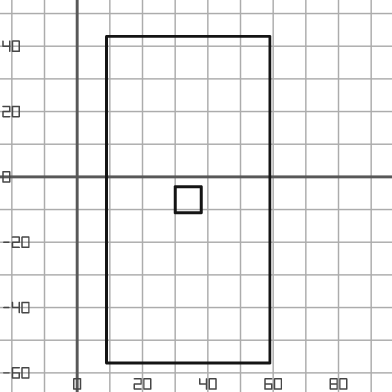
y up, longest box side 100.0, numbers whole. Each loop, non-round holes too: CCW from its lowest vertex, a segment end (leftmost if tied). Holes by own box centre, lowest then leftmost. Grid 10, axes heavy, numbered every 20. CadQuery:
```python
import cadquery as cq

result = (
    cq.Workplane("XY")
    .moveTo(9.0, -57.0)
    .lineTo(59.0, -57.0)
    .lineTo(59.0, 43.0)
    .lineTo(9.0, 43.0)
    .close()
    .moveTo(30.0, -11.0)
    .lineTo(38.0, -11.0)
    .lineTo(38.0, -3.0)
    .lineTo(30.0, -3.0)
    .close()
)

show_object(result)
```